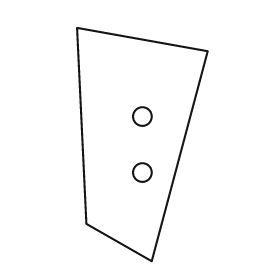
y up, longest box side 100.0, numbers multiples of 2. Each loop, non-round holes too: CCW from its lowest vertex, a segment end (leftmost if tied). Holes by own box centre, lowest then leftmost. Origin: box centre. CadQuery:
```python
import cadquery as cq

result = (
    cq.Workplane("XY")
    .moveTo(4.0, -50.0)
    .lineTo(28.0, 40.0)
    .lineTo(-28.0, 50.0)
    .lineTo(-24.0, -34.0)
    .close()
    .moveTo(0.0, -12.0)
    .circle(4.0)
    .moveTo(0.0, 12.0)
    .circle(4.0)
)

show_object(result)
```